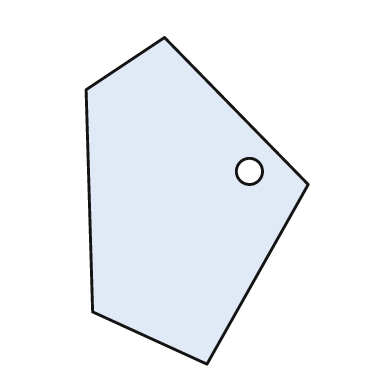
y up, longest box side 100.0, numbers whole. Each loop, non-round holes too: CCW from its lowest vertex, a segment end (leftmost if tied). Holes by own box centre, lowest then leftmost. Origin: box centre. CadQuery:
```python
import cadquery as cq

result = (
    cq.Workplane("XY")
    .moveTo(3.0, -50.0)
    .lineTo(34.0, 5.0)
    .lineTo(-10.0, 50.0)
    .lineTo(-34.0, 34.0)
    .lineTo(-32.0, -34.0)
    .close()
    .moveTo(16.0, 9.0)
    .circle(4.0)
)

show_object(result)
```